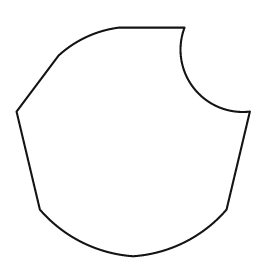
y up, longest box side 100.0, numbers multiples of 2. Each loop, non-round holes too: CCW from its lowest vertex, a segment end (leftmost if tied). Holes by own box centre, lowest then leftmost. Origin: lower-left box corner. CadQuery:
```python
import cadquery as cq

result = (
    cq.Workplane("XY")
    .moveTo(50.0, 0.0)
    .threePointArc((72.0, 6.0), (90.0, 20.0))
    .lineTo(100.0, 62.0)
    .threePointArc((76.0, 72.0), (72.0, 98.0))
    .lineTo(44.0, 98.0)
    .threePointArc((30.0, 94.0), (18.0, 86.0))
    .lineTo(0.0, 62.0)
    .lineTo(10.0, 20.0)
    .threePointArc((28.0, 6.0), (50.0, 0.0))
    .close()
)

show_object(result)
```